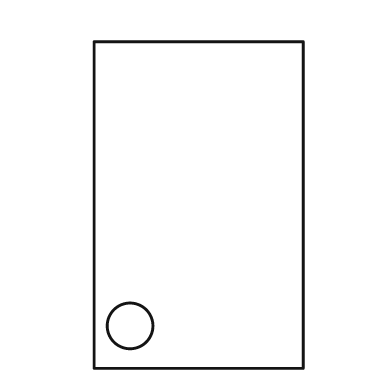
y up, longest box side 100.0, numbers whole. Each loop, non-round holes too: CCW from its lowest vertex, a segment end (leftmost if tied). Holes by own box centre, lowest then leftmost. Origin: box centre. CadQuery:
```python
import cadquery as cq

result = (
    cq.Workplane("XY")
    .moveTo(-32.0, -50.0)
    .lineTo(32.0, -50.0)
    .lineTo(32.0, 50.0)
    .lineTo(-32.0, 50.0)
    .close()
    .moveTo(-21.0, -37.0)
    .circle(7.0)
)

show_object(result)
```